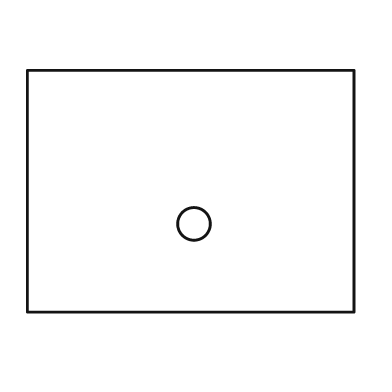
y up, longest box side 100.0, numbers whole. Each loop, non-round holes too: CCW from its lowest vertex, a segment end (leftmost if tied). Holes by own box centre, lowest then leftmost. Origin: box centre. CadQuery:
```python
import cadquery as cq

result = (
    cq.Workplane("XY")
    .moveTo(-50.0, -37.0)
    .lineTo(50.0, -37.0)
    .lineTo(50.0, 37.0)
    .lineTo(-50.0, 37.0)
    .close()
    .moveTo(1.0, -10.0)
    .circle(5.0)
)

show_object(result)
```